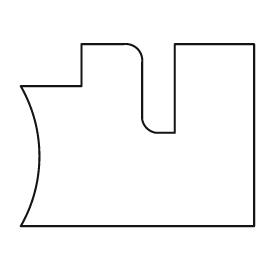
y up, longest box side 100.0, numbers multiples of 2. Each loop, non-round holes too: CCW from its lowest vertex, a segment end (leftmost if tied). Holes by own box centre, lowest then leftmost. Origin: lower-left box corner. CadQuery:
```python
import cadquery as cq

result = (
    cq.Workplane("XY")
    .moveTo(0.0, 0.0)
    .lineTo(100.0, 0.0)
    .lineTo(100.0, 78.0)
    .lineTo(66.0, 78.0)
    .lineTo(66.0, 40.0)
    .lineTo(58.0, 40.0)
    .threePointArc((54.0, 42.0), (52.0, 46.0))
    .lineTo(52.0, 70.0)
    .threePointArc((50.0, 76.0), (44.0, 78.0))
    .lineTo(26.0, 78.0)
    .lineTo(26.0, 60.0)
    .lineTo(0.0, 60.0)
    .threePointArc((8.0, 30.0), (0.0, 0.0))
    .close()
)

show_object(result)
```